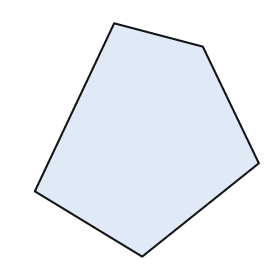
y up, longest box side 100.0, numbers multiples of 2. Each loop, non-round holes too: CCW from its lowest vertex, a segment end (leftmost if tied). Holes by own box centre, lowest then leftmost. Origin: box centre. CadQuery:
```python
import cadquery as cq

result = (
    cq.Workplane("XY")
    .moveTo(-2.0, -50.0)
    .lineTo(48.0, -10.0)
    .lineTo(24.0, 40.0)
    .lineTo(-14.0, 50.0)
    .lineTo(-48.0, -22.0)
    .close()
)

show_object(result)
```